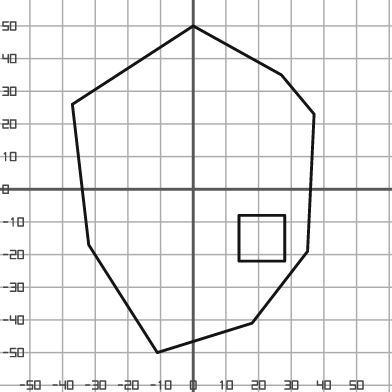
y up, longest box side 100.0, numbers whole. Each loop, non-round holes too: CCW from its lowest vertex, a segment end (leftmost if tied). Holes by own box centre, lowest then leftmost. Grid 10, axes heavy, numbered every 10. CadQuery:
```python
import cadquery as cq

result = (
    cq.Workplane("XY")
    .moveTo(-11.0, -50.0)
    .lineTo(18.0, -41.0)
    .lineTo(35.0, -19.0)
    .lineTo(37.0, 23.0)
    .lineTo(27.0, 35.0)
    .lineTo(0.0, 50.0)
    .lineTo(-37.0, 26.0)
    .lineTo(-32.0, -17.0)
    .close()
    .moveTo(14.0, -22.0)
    .lineTo(28.0, -22.0)
    .lineTo(28.0, -8.0)
    .lineTo(14.0, -8.0)
    .close()
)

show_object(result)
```